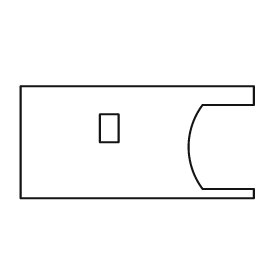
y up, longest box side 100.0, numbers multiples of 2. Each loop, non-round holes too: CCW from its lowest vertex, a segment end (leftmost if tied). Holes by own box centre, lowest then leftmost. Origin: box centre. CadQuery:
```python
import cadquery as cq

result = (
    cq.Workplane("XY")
    .moveTo(-50.0, -24.0)
    .lineTo(50.0, -24.0)
    .lineTo(50.0, -20.0)
    .lineTo(28.0, -20.0)
    .threePointArc((22.0, -2.0), (28.0, 16.0))
    .lineTo(50.0, 16.0)
    .lineTo(50.0, 24.0)
    .lineTo(-50.0, 24.0)
    .close()
    .moveTo(-16.0, 0.0)
    .lineTo(-8.0, 0.0)
    .lineTo(-8.0, 12.0)
    .lineTo(-16.0, 12.0)
    .close()
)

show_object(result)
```